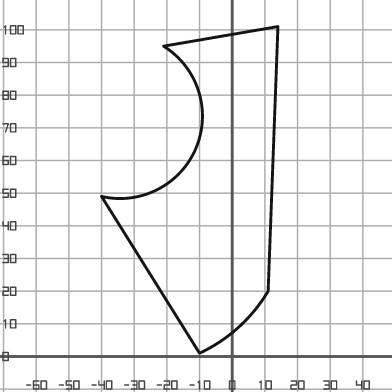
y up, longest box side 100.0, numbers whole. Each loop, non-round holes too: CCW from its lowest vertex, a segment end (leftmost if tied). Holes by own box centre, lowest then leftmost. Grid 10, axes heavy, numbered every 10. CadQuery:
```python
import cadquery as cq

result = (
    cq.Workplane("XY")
    .moveTo(-10.0, 1.0)
    .threePointArc((2.0, 9.0), (11.0, 20.0))
    .lineTo(14.0, 101.0)
    .lineTo(-21.0, 95.0)
    .threePointArc((-11.0, 64.0), (-40.0, 49.0))
    .close()
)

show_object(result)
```